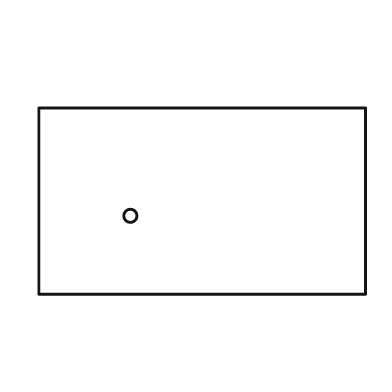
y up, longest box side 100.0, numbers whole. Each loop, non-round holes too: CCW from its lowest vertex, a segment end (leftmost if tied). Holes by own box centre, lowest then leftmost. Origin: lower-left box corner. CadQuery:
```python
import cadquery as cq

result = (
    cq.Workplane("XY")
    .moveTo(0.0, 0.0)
    .lineTo(100.0, 0.0)
    .lineTo(100.0, 57.0)
    .lineTo(0.0, 57.0)
    .close()
    .moveTo(28.0, 24.0)
    .circle(2.0)
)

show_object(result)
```